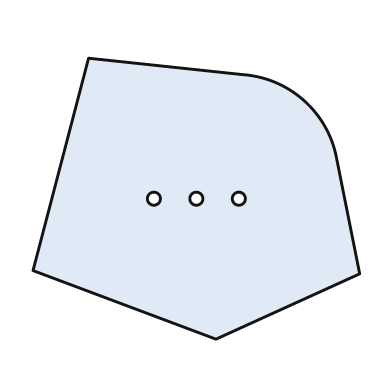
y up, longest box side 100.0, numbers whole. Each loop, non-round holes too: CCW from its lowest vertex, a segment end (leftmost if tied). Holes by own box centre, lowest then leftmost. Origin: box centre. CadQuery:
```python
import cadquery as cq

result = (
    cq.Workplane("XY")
    .moveTo(6.0, -43.0)
    .lineTo(50.0, -23.0)
    .lineTo(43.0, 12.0)
    .threePointArc((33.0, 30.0), (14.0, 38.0))
    .lineTo(-33.0, 43.0)
    .lineTo(-50.0, -22.0)
    .close()
    .moveTo(-13.0, 0.0)
    .circle(2.0)
    .moveTo(0.0, 0.0)
    .circle(2.0)
    .moveTo(13.0, 0.0)
    .circle(2.0)
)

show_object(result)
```